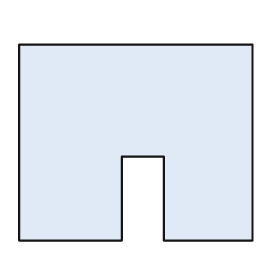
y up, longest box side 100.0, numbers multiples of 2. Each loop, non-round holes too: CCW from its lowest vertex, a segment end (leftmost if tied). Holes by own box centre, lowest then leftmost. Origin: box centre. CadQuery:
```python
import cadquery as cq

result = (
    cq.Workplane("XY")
    .moveTo(-50.0, -42.0)
    .lineTo(-6.0, -42.0)
    .lineTo(-6.0, -6.0)
    .lineTo(12.0, -6.0)
    .lineTo(12.0, -42.0)
    .lineTo(50.0, -42.0)
    .lineTo(50.0, 42.0)
    .lineTo(-50.0, 42.0)
    .close()
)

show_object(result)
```